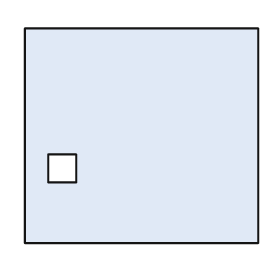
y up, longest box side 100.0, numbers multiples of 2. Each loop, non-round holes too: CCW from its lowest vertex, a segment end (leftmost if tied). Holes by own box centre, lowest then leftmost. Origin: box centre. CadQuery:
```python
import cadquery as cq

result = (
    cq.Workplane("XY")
    .moveTo(-50.0, -46.0)
    .lineTo(50.0, -46.0)
    .lineTo(50.0, 46.0)
    .lineTo(-50.0, 46.0)
    .close()
    .moveTo(-40.0, -20.0)
    .lineTo(-28.0, -20.0)
    .lineTo(-28.0, -8.0)
    .lineTo(-40.0, -8.0)
    .close()
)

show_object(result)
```